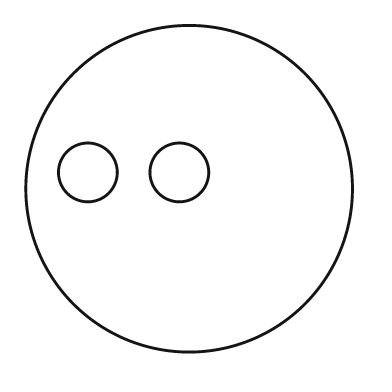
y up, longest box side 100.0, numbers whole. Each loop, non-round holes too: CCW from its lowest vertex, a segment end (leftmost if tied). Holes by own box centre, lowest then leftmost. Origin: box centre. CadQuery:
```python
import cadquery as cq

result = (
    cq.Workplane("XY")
    .moveTo(0.0, 0.0)
    .circle(50.0)
    .moveTo(-31.0, 5.0)
    .circle(9.0)
    .moveTo(-3.0, 5.0)
    .circle(9.0)
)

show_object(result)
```